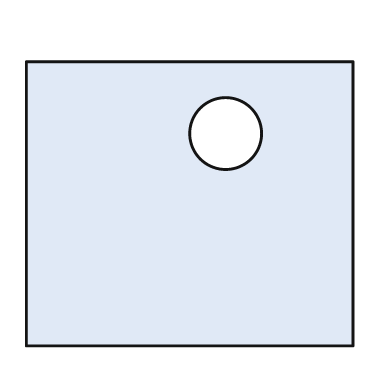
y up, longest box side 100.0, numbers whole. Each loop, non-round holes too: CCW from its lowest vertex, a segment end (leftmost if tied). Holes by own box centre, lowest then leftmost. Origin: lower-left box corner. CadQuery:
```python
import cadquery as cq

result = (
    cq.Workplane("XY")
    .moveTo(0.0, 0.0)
    .lineTo(100.0, 0.0)
    .lineTo(100.0, 87.0)
    .lineTo(0.0, 87.0)
    .close()
    .moveTo(61.0, 65.0)
    .circle(11.0)
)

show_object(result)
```